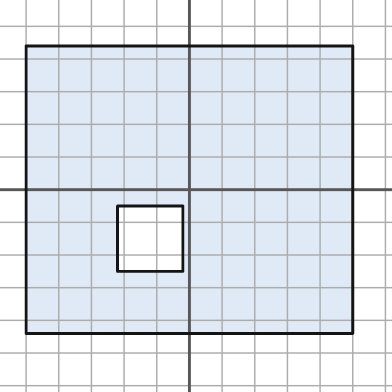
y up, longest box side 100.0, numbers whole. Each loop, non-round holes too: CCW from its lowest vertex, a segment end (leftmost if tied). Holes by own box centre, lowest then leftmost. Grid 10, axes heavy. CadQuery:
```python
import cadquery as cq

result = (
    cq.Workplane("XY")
    .moveTo(-50.0, -44.0)
    .lineTo(50.0, -44.0)
    .lineTo(50.0, 44.0)
    .lineTo(-50.0, 44.0)
    .close()
    .moveTo(-22.0, -25.0)
    .lineTo(-2.0, -25.0)
    .lineTo(-2.0, -5.0)
    .lineTo(-22.0, -5.0)
    .close()
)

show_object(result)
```